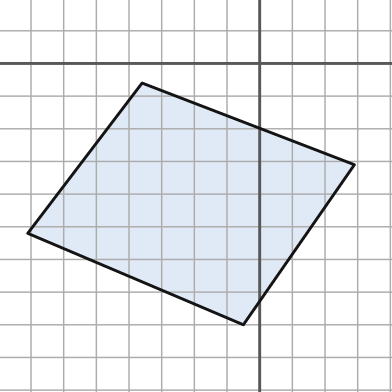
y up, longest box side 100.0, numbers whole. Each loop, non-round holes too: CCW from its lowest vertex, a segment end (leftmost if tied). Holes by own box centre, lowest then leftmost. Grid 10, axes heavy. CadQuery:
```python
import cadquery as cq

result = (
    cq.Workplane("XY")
    .moveTo(-5.0, -80.0)
    .lineTo(29.0, -31.0)
    .lineTo(-36.0, -6.0)
    .lineTo(-71.0, -52.0)
    .close()
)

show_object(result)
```